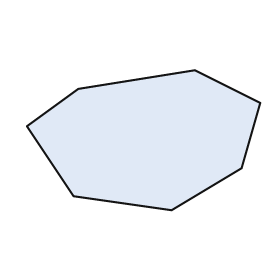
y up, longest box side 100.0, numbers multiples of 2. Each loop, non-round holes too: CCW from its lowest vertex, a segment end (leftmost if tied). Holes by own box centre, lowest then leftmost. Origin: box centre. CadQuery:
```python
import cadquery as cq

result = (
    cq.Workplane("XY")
    .moveTo(12.0, -30.0)
    .lineTo(42.0, -12.0)
    .lineTo(50.0, 16.0)
    .lineTo(22.0, 30.0)
    .lineTo(-28.0, 22.0)
    .lineTo(-50.0, 6.0)
    .lineTo(-30.0, -24.0)
    .close()
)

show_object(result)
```